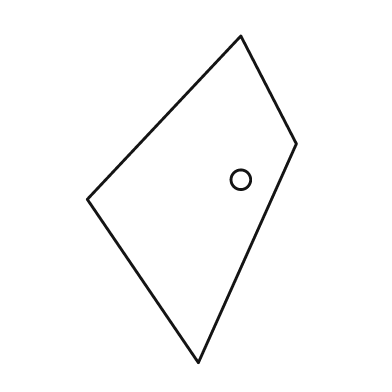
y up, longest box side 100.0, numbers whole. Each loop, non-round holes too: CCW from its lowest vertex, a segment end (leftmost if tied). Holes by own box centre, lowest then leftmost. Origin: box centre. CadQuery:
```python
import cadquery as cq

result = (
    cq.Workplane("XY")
    .moveTo(2.0, -50.0)
    .lineTo(32.0, 17.0)
    .lineTo(15.0, 50.0)
    .lineTo(-32.0, 0.0)
    .close()
    .moveTo(15.0, 6.0)
    .circle(3.0)
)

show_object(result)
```